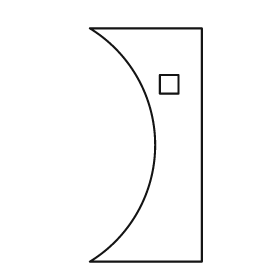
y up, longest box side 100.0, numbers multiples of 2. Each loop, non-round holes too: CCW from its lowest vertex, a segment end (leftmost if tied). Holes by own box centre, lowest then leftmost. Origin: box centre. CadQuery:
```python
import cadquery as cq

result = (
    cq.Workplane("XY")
    .moveTo(-24.0, -50.0)
    .lineTo(24.0, -50.0)
    .lineTo(24.0, 50.0)
    .lineTo(-24.0, 50.0)
    .threePointArc((4.0, 0.0), (-24.0, -50.0))
    .close()
    .moveTo(6.0, 22.0)
    .lineTo(14.0, 22.0)
    .lineTo(14.0, 30.0)
    .lineTo(6.0, 30.0)
    .close()
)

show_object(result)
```